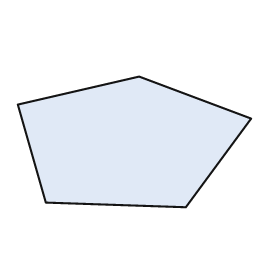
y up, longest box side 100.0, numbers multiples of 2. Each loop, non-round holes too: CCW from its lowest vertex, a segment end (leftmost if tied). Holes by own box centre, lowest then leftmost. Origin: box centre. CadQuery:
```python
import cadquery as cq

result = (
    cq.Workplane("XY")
    .moveTo(22.0, -28.0)
    .lineTo(50.0, 10.0)
    .lineTo(2.0, 28.0)
    .lineTo(-50.0, 16.0)
    .lineTo(-38.0, -26.0)
    .close()
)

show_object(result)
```